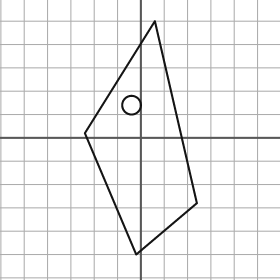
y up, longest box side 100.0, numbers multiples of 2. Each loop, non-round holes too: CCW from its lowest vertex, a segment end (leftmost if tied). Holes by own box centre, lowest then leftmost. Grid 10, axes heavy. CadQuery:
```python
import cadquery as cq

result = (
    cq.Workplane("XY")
    .moveTo(-2.0, -50.0)
    .lineTo(24.0, -28.0)
    .lineTo(6.0, 50.0)
    .lineTo(-24.0, 2.0)
    .close()
    .moveTo(-4.0, 14.0)
    .circle(4.0)
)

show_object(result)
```